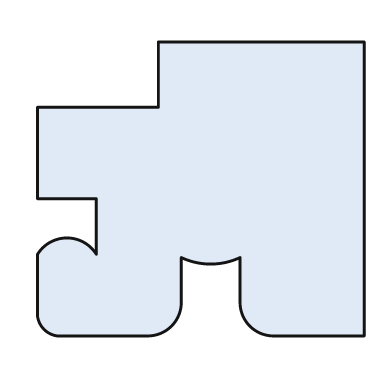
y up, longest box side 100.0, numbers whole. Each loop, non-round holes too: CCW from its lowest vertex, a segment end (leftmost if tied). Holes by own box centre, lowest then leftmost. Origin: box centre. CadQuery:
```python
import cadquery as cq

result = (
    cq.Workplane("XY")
    .moveTo(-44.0, -45.0)
    .lineTo(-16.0, -45.0)
    .threePointArc((-9.0, -42.0), (-6.0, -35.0))
    .lineTo(-6.0, -21.0)
    .threePointArc((3.0, -23.0), (12.0, -21.0))
    .lineTo(12.0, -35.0)
    .threePointArc((15.0, -42.0), (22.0, -45.0))
    .lineTo(50.0, -45.0)
    .lineTo(50.0, 45.0)
    .lineTo(-13.0, 45.0)
    .lineTo(-13.0, 25.0)
    .lineTo(-50.0, 25.0)
    .lineTo(-50.0, -3.0)
    .lineTo(-32.0, -3.0)
    .lineTo(-32.0, -20.0)
    .threePointArc((-41.0, -15.0), (-50.0, -20.0))
    .lineTo(-50.0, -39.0)
    .threePointArc((-48.0, -43.0), (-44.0, -45.0))
    .close()
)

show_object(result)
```